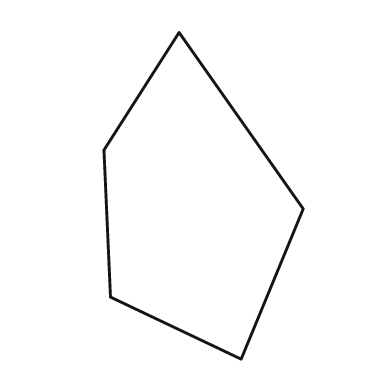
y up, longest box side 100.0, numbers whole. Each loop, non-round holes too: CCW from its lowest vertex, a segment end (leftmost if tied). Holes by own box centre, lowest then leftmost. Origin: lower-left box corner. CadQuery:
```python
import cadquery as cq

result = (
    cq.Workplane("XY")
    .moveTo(42.0, 0.0)
    .lineTo(61.0, 46.0)
    .lineTo(23.0, 100.0)
    .lineTo(0.0, 64.0)
    .lineTo(2.0, 19.0)
    .close()
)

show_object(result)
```